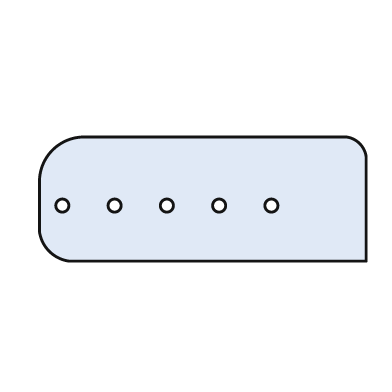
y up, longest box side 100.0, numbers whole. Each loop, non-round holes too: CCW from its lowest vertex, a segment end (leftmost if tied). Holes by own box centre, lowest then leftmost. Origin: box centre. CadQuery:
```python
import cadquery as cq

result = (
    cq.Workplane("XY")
    .moveTo(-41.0, -19.0)
    .lineTo(50.0, -19.0)
    .lineTo(50.0, 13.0)
    .threePointArc((48.0, 17.0), (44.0, 19.0))
    .lineTo(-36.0, 19.0)
    .threePointArc((-46.0, 15.0), (-50.0, 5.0))
    .lineTo(-50.0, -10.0)
    .threePointArc((-47.0, -16.0), (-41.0, -19.0))
    .close()
    .moveTo(-43.0, -2.0)
    .circle(2.0)
    .moveTo(-27.0, -2.0)
    .circle(2.0)
    .moveTo(-11.0, -2.0)
    .circle(2.0)
    .moveTo(5.0, -2.0)
    .circle(2.0)
    .moveTo(21.0, -2.0)
    .circle(2.0)
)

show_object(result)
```